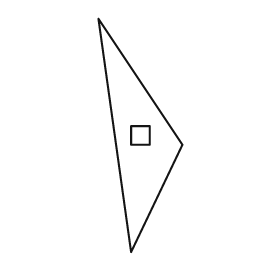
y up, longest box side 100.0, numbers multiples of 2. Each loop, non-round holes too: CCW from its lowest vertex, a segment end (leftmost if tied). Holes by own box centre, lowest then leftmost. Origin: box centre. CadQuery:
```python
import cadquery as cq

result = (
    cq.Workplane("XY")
    .moveTo(-4.0, -50.0)
    .lineTo(18.0, -4.0)
    .lineTo(-18.0, 50.0)
    .close()
    .moveTo(-4.0, -4.0)
    .lineTo(4.0, -4.0)
    .lineTo(4.0, 4.0)
    .lineTo(-4.0, 4.0)
    .close()
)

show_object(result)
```